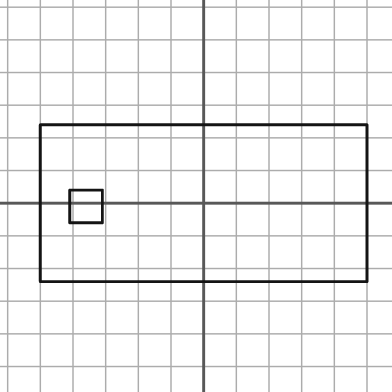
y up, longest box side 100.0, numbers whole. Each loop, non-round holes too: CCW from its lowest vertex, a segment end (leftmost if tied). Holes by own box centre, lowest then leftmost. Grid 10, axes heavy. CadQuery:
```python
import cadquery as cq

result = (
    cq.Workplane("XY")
    .moveTo(-50.0, -24.0)
    .lineTo(50.0, -24.0)
    .lineTo(50.0, 24.0)
    .lineTo(-50.0, 24.0)
    .close()
    .moveTo(-41.0, -6.0)
    .lineTo(-31.0, -6.0)
    .lineTo(-31.0, 4.0)
    .lineTo(-41.0, 4.0)
    .close()
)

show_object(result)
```